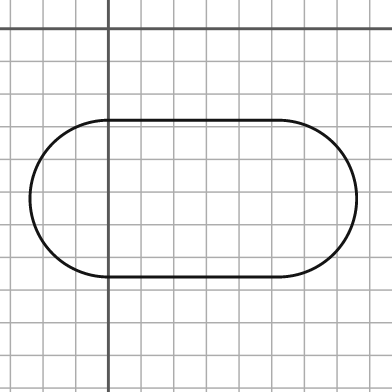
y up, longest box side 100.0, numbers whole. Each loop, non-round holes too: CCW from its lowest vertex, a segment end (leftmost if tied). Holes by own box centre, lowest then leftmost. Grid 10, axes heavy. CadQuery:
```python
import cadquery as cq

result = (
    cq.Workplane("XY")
    .moveTo(0.0, -76.0)
    .lineTo(52.0, -76.0)
    .threePointArc((76.0, -52.0), (52.0, -28.0))
    .lineTo(0.0, -28.0)
    .threePointArc((-24.0, -52.0), (0.0, -76.0))
    .close()
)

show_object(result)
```